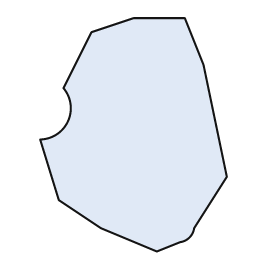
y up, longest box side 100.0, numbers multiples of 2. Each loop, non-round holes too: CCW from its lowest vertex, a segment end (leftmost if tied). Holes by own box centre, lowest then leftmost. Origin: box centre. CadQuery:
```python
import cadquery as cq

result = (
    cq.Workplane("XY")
    .moveTo(10.0, -50.0)
    .lineTo(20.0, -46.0)
    .threePointArc((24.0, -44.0), (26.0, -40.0))
    .lineTo(40.0, -18.0)
    .lineTo(30.0, 30.0)
    .lineTo(22.0, 50.0)
    .lineTo(0.0, 50.0)
    .lineTo(-18.0, 44.0)
    .lineTo(-30.0, 20.0)
    .threePointArc((-28.0, 6.0), (-40.0, -2.0))
    .lineTo(-32.0, -28.0)
    .lineTo(-14.0, -40.0)
    .close()
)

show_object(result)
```